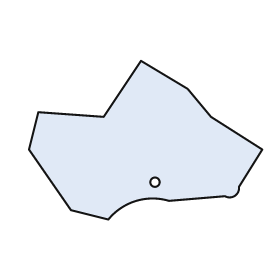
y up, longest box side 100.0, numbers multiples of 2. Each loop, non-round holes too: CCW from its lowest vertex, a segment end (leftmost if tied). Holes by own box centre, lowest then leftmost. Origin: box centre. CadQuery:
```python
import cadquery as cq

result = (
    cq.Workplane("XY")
    .moveTo(-16.0, -34.0)
    .threePointArc((-4.0, -26.0), (10.0, -26.0))
    .lineTo(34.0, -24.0)
    .threePointArc((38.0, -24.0), (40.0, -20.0))
    .lineTo(50.0, -4.0)
    .lineTo(28.0, 10.0)
    .lineTo(18.0, 22.0)
    .lineTo(-2.0, 34.0)
    .lineTo(-18.0, 10.0)
    .lineTo(-46.0, 12.0)
    .lineTo(-50.0, -4.0)
    .lineTo(-32.0, -30.0)
    .close()
    .moveTo(4.0, -18.0)
    .circle(2.0)
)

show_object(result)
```